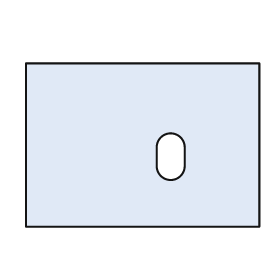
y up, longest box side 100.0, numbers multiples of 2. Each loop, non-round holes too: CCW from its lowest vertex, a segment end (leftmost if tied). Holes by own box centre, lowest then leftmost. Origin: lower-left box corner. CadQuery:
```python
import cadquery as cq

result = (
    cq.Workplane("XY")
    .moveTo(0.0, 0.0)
    .lineTo(100.0, 0.0)
    .lineTo(100.0, 70.0)
    .lineTo(0.0, 70.0)
    .close()
    .moveTo(56.0, 26.0)
    .threePointArc((62.0, 20.0), (68.0, 26.0))
    .lineTo(68.0, 34.0)
    .threePointArc((62.0, 40.0), (56.0, 34.0))
    .close()
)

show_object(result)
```